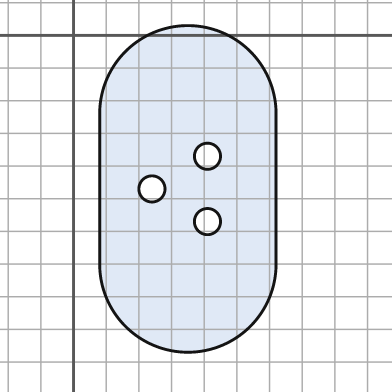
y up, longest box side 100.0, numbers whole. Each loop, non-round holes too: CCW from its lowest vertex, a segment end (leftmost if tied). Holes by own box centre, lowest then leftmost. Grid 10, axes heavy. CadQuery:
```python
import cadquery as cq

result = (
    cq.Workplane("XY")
    .moveTo(8.0, -70.0)
    .threePointArc((35.0, -97.0), (62.0, -70.0))
    .lineTo(62.0, -24.0)
    .threePointArc((35.0, 3.0), (8.0, -24.0))
    .close()
    .moveTo(41.0, -57.0)
    .circle(4.0)
    .moveTo(24.0, -47.0)
    .circle(4.0)
    .moveTo(41.0, -37.0)
    .circle(4.0)
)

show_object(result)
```